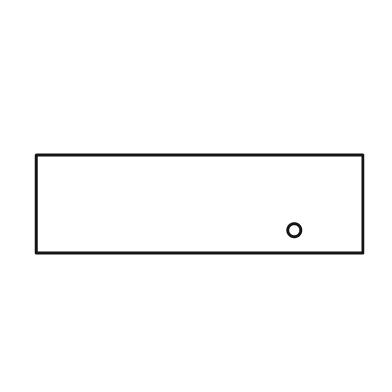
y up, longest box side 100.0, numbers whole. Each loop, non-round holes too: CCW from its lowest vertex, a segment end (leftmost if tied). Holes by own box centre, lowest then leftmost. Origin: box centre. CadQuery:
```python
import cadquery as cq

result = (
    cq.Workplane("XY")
    .moveTo(-50.0, -15.0)
    .lineTo(50.0, -15.0)
    .lineTo(50.0, 15.0)
    .lineTo(-50.0, 15.0)
    .close()
    .moveTo(29.0, -8.0)
    .circle(2.0)
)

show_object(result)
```